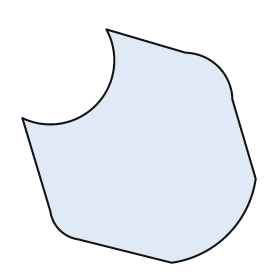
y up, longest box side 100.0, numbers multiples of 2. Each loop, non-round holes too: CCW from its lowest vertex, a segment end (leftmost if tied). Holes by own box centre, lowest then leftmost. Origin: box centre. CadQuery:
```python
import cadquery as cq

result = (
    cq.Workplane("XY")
    .moveTo(14.0, -50.0)
    .threePointArc((38.0, -38.0), (50.0, -14.0))
    .lineTo(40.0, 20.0)
    .threePointArc((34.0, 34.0), (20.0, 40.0))
    .lineTo(-14.0, 50.0)
    .threePointArc((-18.0, 18.0), (-50.0, 12.0))
    .lineTo(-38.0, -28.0)
    .threePointArc((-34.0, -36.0), (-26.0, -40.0))
    .close()
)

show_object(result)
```